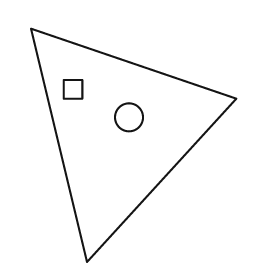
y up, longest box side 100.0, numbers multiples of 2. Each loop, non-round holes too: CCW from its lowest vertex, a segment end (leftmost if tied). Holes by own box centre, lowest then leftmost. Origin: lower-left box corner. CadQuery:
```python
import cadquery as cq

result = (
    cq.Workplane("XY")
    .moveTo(24.0, 0.0)
    .lineTo(88.0, 70.0)
    .lineTo(0.0, 100.0)
    .close()
    .moveTo(42.0, 62.0)
    .circle(6.0)
    .moveTo(14.0, 70.0)
    .lineTo(22.0, 70.0)
    .lineTo(22.0, 78.0)
    .lineTo(14.0, 78.0)
    .close()
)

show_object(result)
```